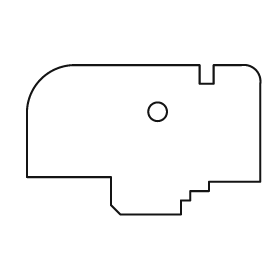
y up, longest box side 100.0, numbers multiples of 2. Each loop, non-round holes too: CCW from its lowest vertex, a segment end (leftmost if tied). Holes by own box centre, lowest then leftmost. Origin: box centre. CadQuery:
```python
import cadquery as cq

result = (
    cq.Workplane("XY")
    .moveTo(-10.0, -32.0)
    .lineTo(16.0, -32.0)
    .lineTo(16.0, -26.0)
    .lineTo(20.0, -26.0)
    .lineTo(20.0, -22.0)
    .lineTo(28.0, -22.0)
    .lineTo(28.0, -18.0)
    .lineTo(50.0, -18.0)
    .lineTo(50.0, 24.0)
    .threePointArc((48.0, 30.0), (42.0, 32.0))
    .lineTo(30.0, 32.0)
    .lineTo(30.0, 24.0)
    .lineTo(24.0, 24.0)
    .lineTo(24.0, 32.0)
    .lineTo(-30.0, 32.0)
    .threePointArc((-44.0, 26.0), (-50.0, 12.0))
    .lineTo(-50.0, -16.0)
    .lineTo(-14.0, -16.0)
    .lineTo(-14.0, -28.0)
    .close()
    .moveTo(6.0, 12.0)
    .circle(4.0)
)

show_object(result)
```